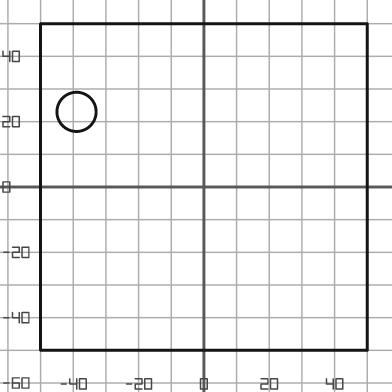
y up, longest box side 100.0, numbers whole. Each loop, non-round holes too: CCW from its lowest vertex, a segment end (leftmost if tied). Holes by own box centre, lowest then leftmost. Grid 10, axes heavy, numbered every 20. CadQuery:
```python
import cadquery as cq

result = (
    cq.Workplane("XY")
    .moveTo(-50.0, -50.0)
    .lineTo(50.0, -50.0)
    .lineTo(50.0, 50.0)
    .lineTo(-50.0, 50.0)
    .close()
    .moveTo(-39.0, 23.0)
    .circle(6.0)
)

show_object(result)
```